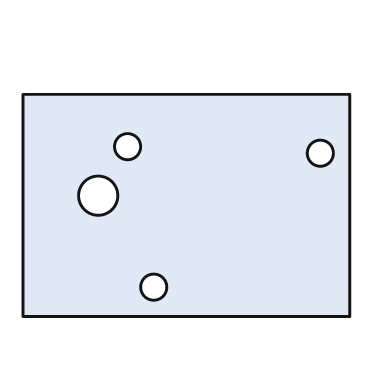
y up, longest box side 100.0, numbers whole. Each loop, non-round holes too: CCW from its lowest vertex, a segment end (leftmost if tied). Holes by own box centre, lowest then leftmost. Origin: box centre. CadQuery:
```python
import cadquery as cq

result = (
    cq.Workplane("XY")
    .moveTo(-50.0, -34.0)
    .lineTo(50.0, -34.0)
    .lineTo(50.0, 34.0)
    .lineTo(-50.0, 34.0)
    .close()
    .moveTo(-10.0, -25.0)
    .circle(4.0)
    .moveTo(-27.0, 3.0)
    .circle(6.0)
    .moveTo(41.0, 16.0)
    .circle(4.0)
    .moveTo(-18.0, 18.0)
    .circle(4.0)
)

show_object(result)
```